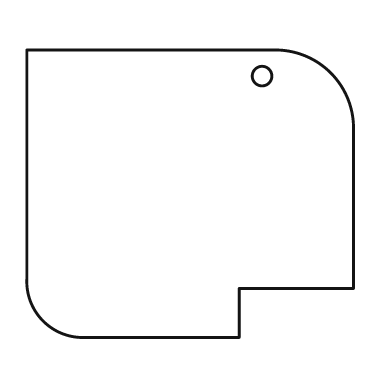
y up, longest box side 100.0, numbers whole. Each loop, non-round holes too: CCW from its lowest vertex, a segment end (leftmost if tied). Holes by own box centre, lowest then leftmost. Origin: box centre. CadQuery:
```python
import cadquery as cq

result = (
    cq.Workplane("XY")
    .moveTo(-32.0, -44.0)
    .lineTo(15.0, -44.0)
    .lineTo(15.0, -29.0)
    .lineTo(50.0, -29.0)
    .lineTo(50.0, 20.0)
    .threePointArc((43.0, 37.0), (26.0, 44.0))
    .lineTo(-50.0, 44.0)
    .lineTo(-50.0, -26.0)
    .threePointArc((-45.0, -39.0), (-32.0, -44.0))
    .close()
    .moveTo(22.0, 36.0)
    .circle(3.0)
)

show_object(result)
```